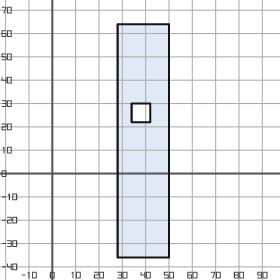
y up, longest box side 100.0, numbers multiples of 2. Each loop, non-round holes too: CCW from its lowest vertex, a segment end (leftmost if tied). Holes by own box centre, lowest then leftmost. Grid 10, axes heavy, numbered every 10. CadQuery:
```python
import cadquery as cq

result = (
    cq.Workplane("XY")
    .moveTo(28.0, -36.0)
    .lineTo(50.0, -36.0)
    .lineTo(50.0, 64.0)
    .lineTo(28.0, 64.0)
    .close()
    .moveTo(34.0, 22.0)
    .lineTo(42.0, 22.0)
    .lineTo(42.0, 30.0)
    .lineTo(34.0, 30.0)
    .close()
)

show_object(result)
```